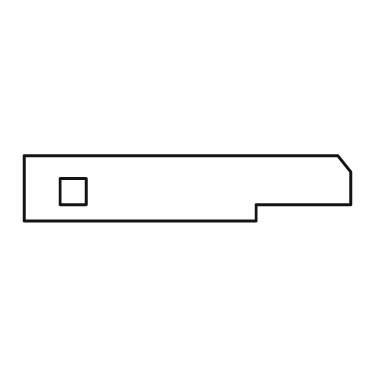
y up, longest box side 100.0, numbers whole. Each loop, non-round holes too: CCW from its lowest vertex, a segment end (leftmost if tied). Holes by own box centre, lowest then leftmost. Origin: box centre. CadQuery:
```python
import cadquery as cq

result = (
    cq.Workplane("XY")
    .moveTo(-50.0, -10.0)
    .lineTo(21.0, -10.0)
    .lineTo(21.0, -5.0)
    .lineTo(50.0, -5.0)
    .lineTo(50.0, 5.0)
    .lineTo(46.0, 10.0)
    .lineTo(-50.0, 10.0)
    .close()
    .moveTo(-39.0, -5.0)
    .lineTo(-31.0, -5.0)
    .lineTo(-31.0, 3.0)
    .lineTo(-39.0, 3.0)
    .close()
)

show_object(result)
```